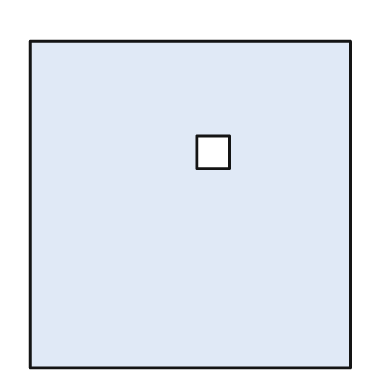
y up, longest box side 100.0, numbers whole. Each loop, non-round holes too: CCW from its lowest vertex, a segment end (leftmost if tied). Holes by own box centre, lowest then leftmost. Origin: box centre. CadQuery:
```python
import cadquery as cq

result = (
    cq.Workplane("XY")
    .moveTo(-49.0, -50.0)
    .lineTo(49.0, -50.0)
    .lineTo(49.0, 50.0)
    .lineTo(-49.0, 50.0)
    .close()
    .moveTo(2.0, 11.0)
    .lineTo(12.0, 11.0)
    .lineTo(12.0, 21.0)
    .lineTo(2.0, 21.0)
    .close()
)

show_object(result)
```